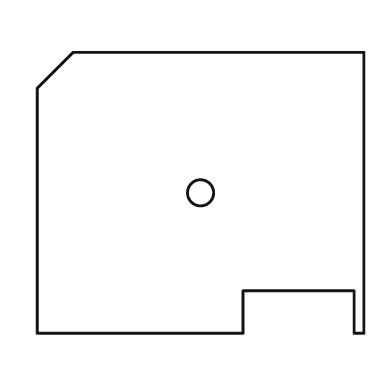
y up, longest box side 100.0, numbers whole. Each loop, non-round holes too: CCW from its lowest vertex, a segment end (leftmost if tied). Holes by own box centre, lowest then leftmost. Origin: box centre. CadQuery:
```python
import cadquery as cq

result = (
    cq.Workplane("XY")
    .moveTo(-50.0, -43.0)
    .lineTo(13.0, -43.0)
    .lineTo(13.0, -30.0)
    .lineTo(47.0, -30.0)
    .lineTo(47.0, -43.0)
    .lineTo(50.0, -43.0)
    .lineTo(50.0, 43.0)
    .lineTo(-39.0, 43.0)
    .lineTo(-50.0, 32.0)
    .close()
    .moveTo(0.0, 0.0)
    .circle(4.0)
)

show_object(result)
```